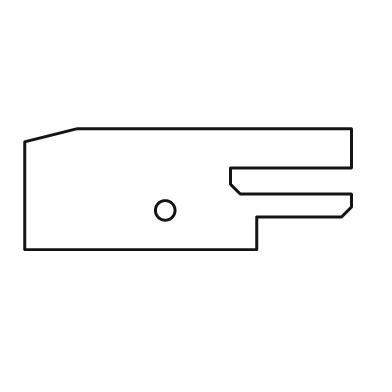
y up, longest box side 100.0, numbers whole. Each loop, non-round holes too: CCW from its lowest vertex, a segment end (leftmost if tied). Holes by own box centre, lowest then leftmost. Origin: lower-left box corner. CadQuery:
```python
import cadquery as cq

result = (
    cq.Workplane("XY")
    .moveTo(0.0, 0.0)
    .lineTo(71.0, 0.0)
    .lineTo(71.0, 10.0)
    .lineTo(97.0, 10.0)
    .lineTo(100.0, 13.0)
    .lineTo(100.0, 17.0)
    .lineTo(66.0, 17.0)
    .lineTo(63.0, 20.0)
    .lineTo(63.0, 25.0)
    .lineTo(100.0, 25.0)
    .lineTo(100.0, 37.0)
    .lineTo(16.0, 37.0)
    .lineTo(0.0, 33.0)
    .close()
    .moveTo(43.0, 12.0)
    .circle(3.0)
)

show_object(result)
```